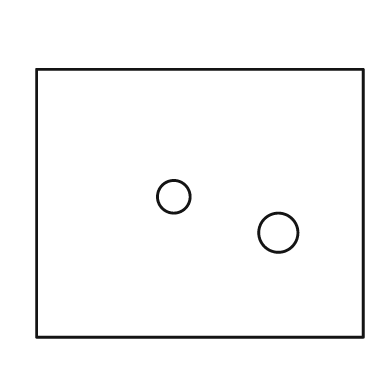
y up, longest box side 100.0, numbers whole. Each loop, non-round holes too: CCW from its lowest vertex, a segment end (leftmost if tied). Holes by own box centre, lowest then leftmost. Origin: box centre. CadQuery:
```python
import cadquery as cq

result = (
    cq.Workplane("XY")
    .moveTo(-50.0, -41.0)
    .lineTo(50.0, -41.0)
    .lineTo(50.0, 41.0)
    .lineTo(-50.0, 41.0)
    .close()
    .moveTo(24.0, -9.0)
    .circle(6.0)
    .moveTo(-8.0, 2.0)
    .circle(5.0)
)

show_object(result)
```